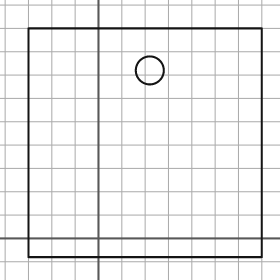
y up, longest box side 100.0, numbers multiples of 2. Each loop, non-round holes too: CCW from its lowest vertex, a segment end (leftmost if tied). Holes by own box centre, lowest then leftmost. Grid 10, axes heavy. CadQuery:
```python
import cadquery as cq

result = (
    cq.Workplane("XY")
    .moveTo(-30.0, -8.0)
    .lineTo(70.0, -8.0)
    .lineTo(70.0, 90.0)
    .lineTo(-30.0, 90.0)
    .close()
    .moveTo(22.0, 72.0)
    .circle(6.0)
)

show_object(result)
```